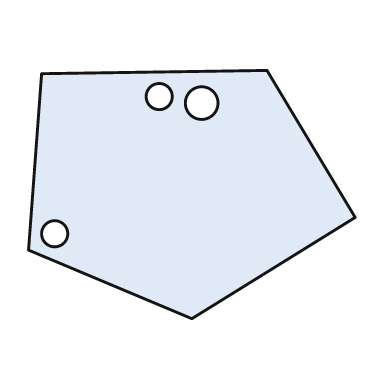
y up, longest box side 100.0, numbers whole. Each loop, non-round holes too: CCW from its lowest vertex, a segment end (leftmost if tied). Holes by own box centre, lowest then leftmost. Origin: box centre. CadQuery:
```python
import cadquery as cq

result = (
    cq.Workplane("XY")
    .moveTo(0.0, -38.0)
    .lineTo(50.0, -7.0)
    .lineTo(23.0, 38.0)
    .lineTo(-46.0, 37.0)
    .lineTo(-50.0, -17.0)
    .close()
    .moveTo(-42.0, -12.0)
    .circle(4.0)
    .moveTo(3.0, 28.0)
    .circle(5.0)
    .moveTo(-10.0, 30.0)
    .circle(4.0)
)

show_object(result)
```